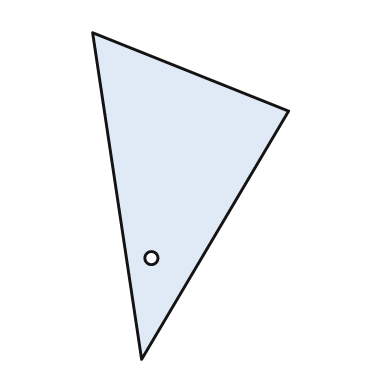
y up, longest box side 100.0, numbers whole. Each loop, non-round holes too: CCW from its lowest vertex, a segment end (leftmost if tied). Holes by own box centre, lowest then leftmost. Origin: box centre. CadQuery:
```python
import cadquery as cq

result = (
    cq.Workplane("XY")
    .moveTo(-15.0, -50.0)
    .lineTo(30.0, 26.0)
    .lineTo(-30.0, 50.0)
    .close()
    .moveTo(-12.0, -19.0)
    .circle(2.0)
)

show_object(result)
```